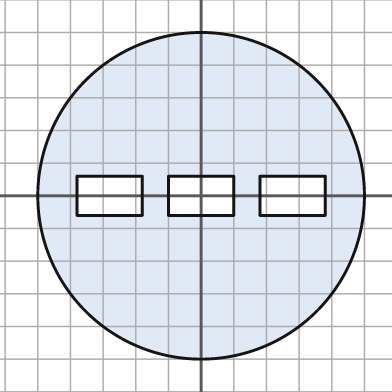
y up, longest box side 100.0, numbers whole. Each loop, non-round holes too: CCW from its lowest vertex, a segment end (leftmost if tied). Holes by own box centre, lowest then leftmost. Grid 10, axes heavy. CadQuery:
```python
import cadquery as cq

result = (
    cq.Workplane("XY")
    .moveTo(0.0, 0.0)
    .circle(50.0)
    .moveTo(-38.0, -6.0)
    .lineTo(-18.0, -6.0)
    .lineTo(-18.0, 6.0)
    .lineTo(-38.0, 6.0)
    .close()
    .moveTo(-10.0, -6.0)
    .lineTo(10.0, -6.0)
    .lineTo(10.0, 6.0)
    .lineTo(-10.0, 6.0)
    .close()
    .moveTo(18.0, -6.0)
    .lineTo(38.0, -6.0)
    .lineTo(38.0, 6.0)
    .lineTo(18.0, 6.0)
    .close()
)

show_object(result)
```